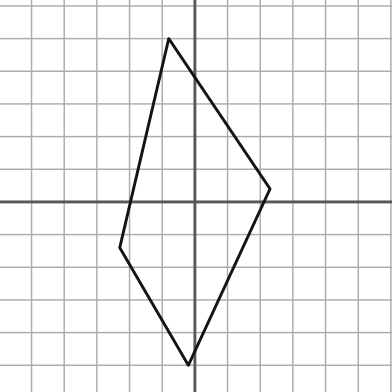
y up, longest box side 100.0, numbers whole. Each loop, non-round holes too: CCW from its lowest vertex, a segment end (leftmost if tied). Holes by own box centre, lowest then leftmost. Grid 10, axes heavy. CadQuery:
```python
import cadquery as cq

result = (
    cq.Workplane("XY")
    .moveTo(-2.0, -50.0)
    .lineTo(23.0, 4.0)
    .lineTo(-8.0, 50.0)
    .lineTo(-23.0, -14.0)
    .close()
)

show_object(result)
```